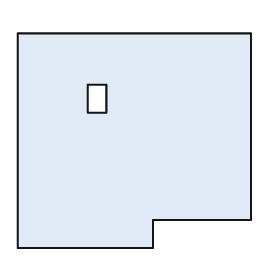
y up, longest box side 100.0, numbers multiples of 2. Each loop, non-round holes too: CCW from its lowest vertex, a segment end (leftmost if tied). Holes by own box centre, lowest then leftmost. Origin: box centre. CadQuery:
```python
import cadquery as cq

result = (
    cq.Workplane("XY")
    .moveTo(-50.0, -46.0)
    .lineTo(8.0, -46.0)
    .lineTo(8.0, -34.0)
    .lineTo(50.0, -34.0)
    .lineTo(50.0, 46.0)
    .lineTo(-50.0, 46.0)
    .close()
    .moveTo(-20.0, 12.0)
    .lineTo(-12.0, 12.0)
    .lineTo(-12.0, 24.0)
    .lineTo(-20.0, 24.0)
    .close()
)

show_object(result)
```